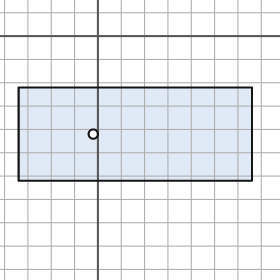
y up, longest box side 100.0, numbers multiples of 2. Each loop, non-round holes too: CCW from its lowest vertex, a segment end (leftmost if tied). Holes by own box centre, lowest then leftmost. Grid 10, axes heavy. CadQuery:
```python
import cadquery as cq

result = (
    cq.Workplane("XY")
    .moveTo(-34.0, -62.0)
    .lineTo(66.0, -62.0)
    .lineTo(66.0, -22.0)
    .lineTo(-34.0, -22.0)
    .close()
    .moveTo(-2.0, -42.0)
    .circle(2.0)
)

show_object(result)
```